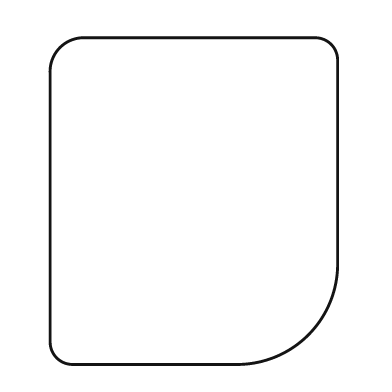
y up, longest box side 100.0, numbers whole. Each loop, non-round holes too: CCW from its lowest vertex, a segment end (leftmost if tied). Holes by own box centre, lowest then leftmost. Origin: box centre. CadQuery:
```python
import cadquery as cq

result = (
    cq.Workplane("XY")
    .moveTo(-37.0, -50.0)
    .lineTo(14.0, -50.0)
    .threePointArc((35.0, -41.0), (44.0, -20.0))
    .lineTo(44.0, 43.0)
    .threePointArc((42.0, 48.0), (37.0, 50.0))
    .lineTo(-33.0, 50.0)
    .threePointArc((-41.0, 47.0), (-44.0, 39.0))
    .lineTo(-44.0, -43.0)
    .threePointArc((-42.0, -48.0), (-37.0, -50.0))
    .close()
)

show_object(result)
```